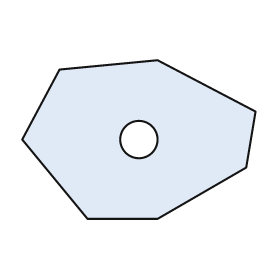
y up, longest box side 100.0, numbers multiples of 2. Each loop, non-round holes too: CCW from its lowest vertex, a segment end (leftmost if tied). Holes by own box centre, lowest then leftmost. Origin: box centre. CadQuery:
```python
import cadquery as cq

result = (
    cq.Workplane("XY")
    .moveTo(-22.0, -34.0)
    .lineTo(8.0, -34.0)
    .lineTo(46.0, -12.0)
    .lineTo(50.0, 12.0)
    .lineTo(8.0, 34.0)
    .lineTo(-34.0, 30.0)
    .lineTo(-50.0, 0.0)
    .close()
    .moveTo(0.0, 0.0)
    .circle(8.0)
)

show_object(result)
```